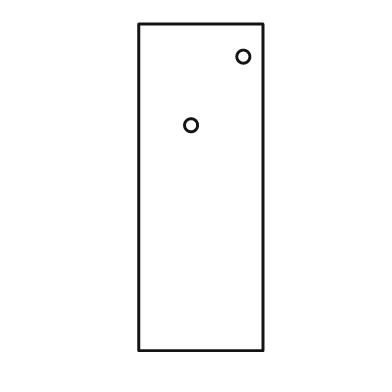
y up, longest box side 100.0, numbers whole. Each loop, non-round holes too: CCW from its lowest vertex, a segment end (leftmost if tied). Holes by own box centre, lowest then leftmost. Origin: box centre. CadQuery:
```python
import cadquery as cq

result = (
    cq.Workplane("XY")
    .moveTo(-19.0, -50.0)
    .lineTo(19.0, -50.0)
    .lineTo(19.0, 50.0)
    .lineTo(-19.0, 50.0)
    .close()
    .moveTo(-3.0, 19.0)
    .circle(2.0)
    .moveTo(13.0, 40.0)
    .circle(2.0)
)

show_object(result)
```